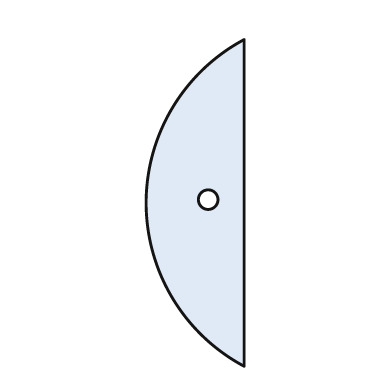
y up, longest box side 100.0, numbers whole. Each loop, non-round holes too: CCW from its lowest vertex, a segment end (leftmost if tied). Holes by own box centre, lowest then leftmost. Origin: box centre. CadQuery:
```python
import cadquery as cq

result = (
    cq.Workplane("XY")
    .moveTo(15.0, -50.0)
    .lineTo(15.0, 50.0)
    .threePointArc((-15.0, 0.0), (15.0, -50.0))
    .close()
    .moveTo(4.0, 1.0)
    .circle(3.0)
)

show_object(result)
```